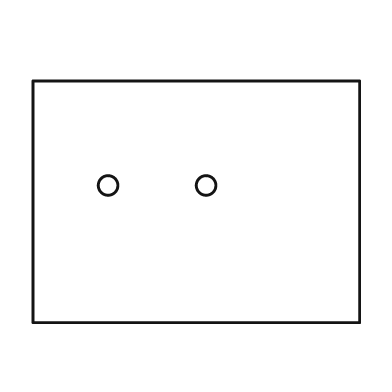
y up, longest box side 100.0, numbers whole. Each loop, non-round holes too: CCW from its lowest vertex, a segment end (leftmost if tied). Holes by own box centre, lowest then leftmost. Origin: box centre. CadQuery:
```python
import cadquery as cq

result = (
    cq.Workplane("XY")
    .moveTo(-50.0, -37.0)
    .lineTo(50.0, -37.0)
    .lineTo(50.0, 37.0)
    .lineTo(-50.0, 37.0)
    .close()
    .moveTo(-27.0, 5.0)
    .circle(3.0)
    .moveTo(3.0, 5.0)
    .circle(3.0)
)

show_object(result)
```